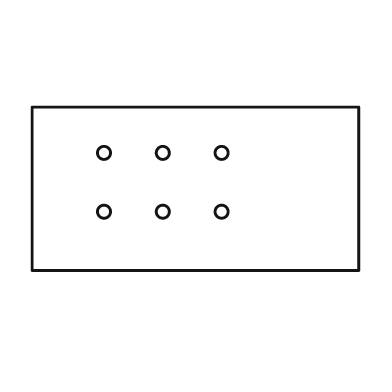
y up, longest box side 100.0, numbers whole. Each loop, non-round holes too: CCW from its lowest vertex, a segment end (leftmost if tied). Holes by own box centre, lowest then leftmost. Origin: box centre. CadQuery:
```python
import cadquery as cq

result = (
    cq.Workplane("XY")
    .moveTo(-50.0, -25.0)
    .lineTo(50.0, -25.0)
    .lineTo(50.0, 25.0)
    .lineTo(-50.0, 25.0)
    .close()
    .moveTo(-28.0, -7.0)
    .circle(2.0)
    .moveTo(-10.0, -7.0)
    .circle(2.0)
    .moveTo(8.0, -7.0)
    .circle(2.0)
    .moveTo(-28.0, 11.0)
    .circle(2.0)
    .moveTo(-10.0, 11.0)
    .circle(2.0)
    .moveTo(8.0, 11.0)
    .circle(2.0)
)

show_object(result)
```